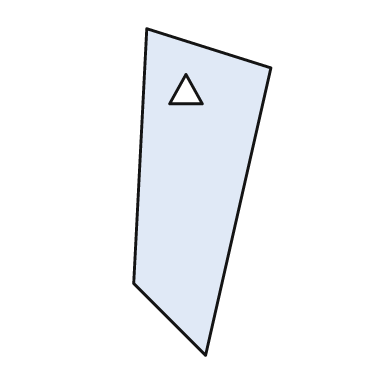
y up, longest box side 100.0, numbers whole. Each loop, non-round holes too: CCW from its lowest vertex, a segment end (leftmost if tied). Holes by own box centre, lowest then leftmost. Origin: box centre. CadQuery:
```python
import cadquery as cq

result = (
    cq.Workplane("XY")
    .moveTo(1.0, -50.0)
    .lineTo(21.0, 38.0)
    .lineTo(-17.0, 50.0)
    .lineTo(-21.0, -28.0)
    .close()
    .moveTo(-10.0, 27.0)
    .lineTo(0.0, 27.0)
    .lineTo(-5.0, 36.0)
    .close()
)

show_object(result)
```